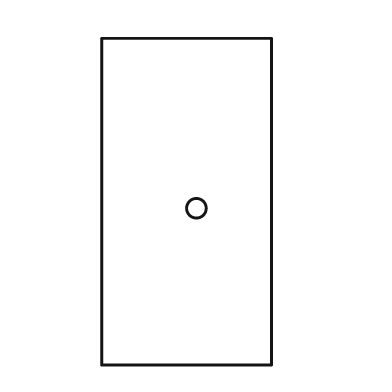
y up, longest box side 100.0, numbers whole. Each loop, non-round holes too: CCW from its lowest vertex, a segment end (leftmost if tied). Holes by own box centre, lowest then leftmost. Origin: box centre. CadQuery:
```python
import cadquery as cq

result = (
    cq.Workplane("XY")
    .moveTo(-26.0, -50.0)
    .lineTo(26.0, -50.0)
    .lineTo(26.0, 50.0)
    .lineTo(-26.0, 50.0)
    .close()
    .moveTo(3.0, -2.0)
    .circle(3.0)
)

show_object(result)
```